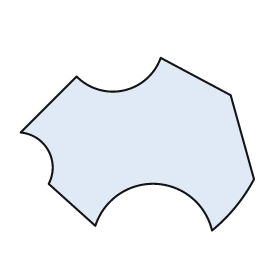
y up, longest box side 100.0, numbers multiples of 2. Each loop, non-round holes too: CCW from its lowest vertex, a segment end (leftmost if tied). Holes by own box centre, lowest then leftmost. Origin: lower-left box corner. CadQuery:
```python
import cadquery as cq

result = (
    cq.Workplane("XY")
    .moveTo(82.0, 0.0)
    .threePointArc((92.0, 10.0), (100.0, 22.0))
    .lineTo(90.0, 58.0)
    .lineTo(60.0, 74.0)
    .threePointArc((44.0, 60.0), (24.0, 66.0))
    .lineTo(0.0, 42.0)
    .threePointArc((12.0, 34.0), (12.0, 20.0))
    .lineTo(32.0, 2.0)
    .threePointArc((58.0, 20.0), (82.0, 0.0))
    .close()
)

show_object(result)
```